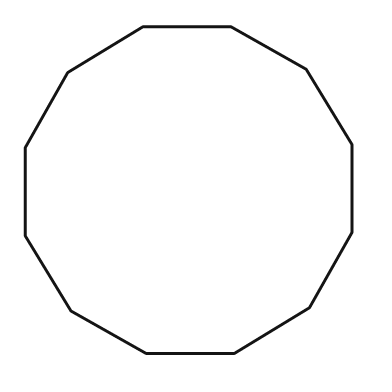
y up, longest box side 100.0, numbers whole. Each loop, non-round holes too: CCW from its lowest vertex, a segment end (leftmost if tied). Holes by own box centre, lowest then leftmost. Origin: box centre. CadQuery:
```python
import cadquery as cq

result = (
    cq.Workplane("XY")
    .moveTo(-13.0, -50.0)
    .lineTo(14.0, -50.0)
    .lineTo(37.0, -36.0)
    .lineTo(50.0, -13.0)
    .lineTo(50.0, 14.0)
    .lineTo(36.0, 37.0)
    .lineTo(13.0, 50.0)
    .lineTo(-14.0, 50.0)
    .lineTo(-37.0, 36.0)
    .lineTo(-50.0, 13.0)
    .lineTo(-50.0, -14.0)
    .lineTo(-36.0, -37.0)
    .close()
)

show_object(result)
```